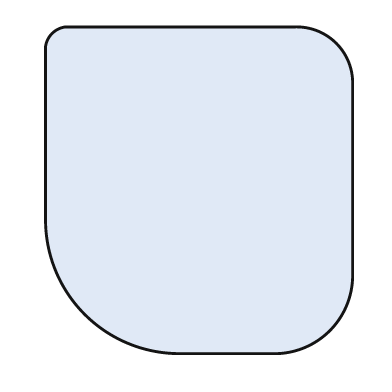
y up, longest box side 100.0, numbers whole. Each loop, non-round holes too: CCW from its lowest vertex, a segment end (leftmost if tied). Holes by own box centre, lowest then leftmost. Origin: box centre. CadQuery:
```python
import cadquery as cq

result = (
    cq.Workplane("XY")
    .moveTo(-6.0, -50.0)
    .lineTo(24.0, -50.0)
    .threePointArc((40.0, -43.0), (47.0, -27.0))
    .lineTo(47.0, 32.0)
    .threePointArc((42.0, 45.0), (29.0, 50.0))
    .lineTo(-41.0, 50.0)
    .threePointArc((-45.0, 48.0), (-47.0, 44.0))
    .lineTo(-47.0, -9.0)
    .threePointArc((-35.0, -38.0), (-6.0, -50.0))
    .close()
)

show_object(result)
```